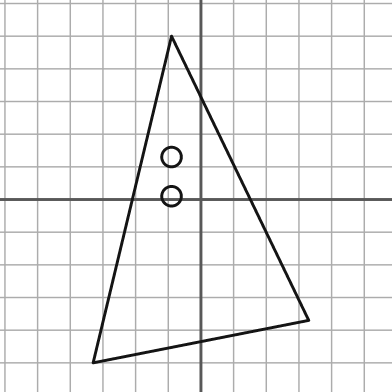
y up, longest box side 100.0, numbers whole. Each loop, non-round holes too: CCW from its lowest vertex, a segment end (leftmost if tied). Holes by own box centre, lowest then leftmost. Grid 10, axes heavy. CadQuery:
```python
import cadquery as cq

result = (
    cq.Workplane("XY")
    .moveTo(-33.0, -50.0)
    .lineTo(33.0, -37.0)
    .lineTo(-9.0, 50.0)
    .close()
    .moveTo(-9.0, 1.0)
    .circle(3.0)
    .moveTo(-9.0, 13.0)
    .circle(3.0)
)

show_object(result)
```